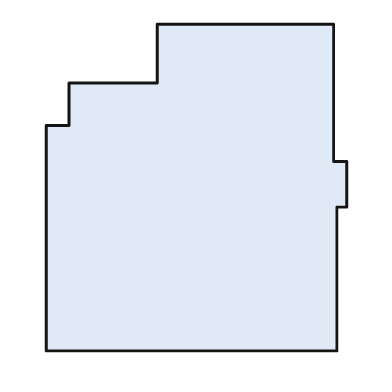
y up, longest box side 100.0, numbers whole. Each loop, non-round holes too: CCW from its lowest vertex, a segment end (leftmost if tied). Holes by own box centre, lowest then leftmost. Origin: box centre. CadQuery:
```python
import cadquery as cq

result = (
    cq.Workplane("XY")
    .moveTo(-46.0, -50.0)
    .lineTo(43.0, -50.0)
    .lineTo(43.0, -6.0)
    .lineTo(46.0, -6.0)
    .lineTo(46.0, 8.0)
    .lineTo(42.0, 8.0)
    .lineTo(42.0, 50.0)
    .lineTo(-12.0, 50.0)
    .lineTo(-12.0, 32.0)
    .lineTo(-39.0, 32.0)
    .lineTo(-39.0, 19.0)
    .lineTo(-46.0, 19.0)
    .close()
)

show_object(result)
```